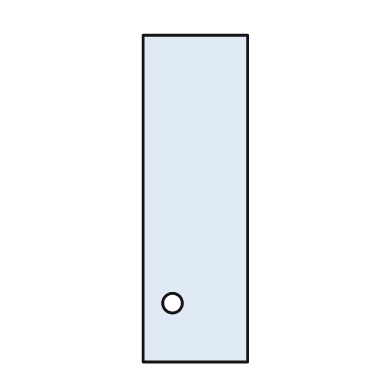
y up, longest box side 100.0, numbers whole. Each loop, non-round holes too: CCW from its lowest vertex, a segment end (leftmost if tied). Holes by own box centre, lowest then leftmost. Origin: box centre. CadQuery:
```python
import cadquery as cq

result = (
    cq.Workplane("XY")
    .moveTo(-16.0, -50.0)
    .lineTo(16.0, -50.0)
    .lineTo(16.0, 50.0)
    .lineTo(-16.0, 50.0)
    .close()
    .moveTo(-7.0, -32.0)
    .circle(3.0)
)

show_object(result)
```